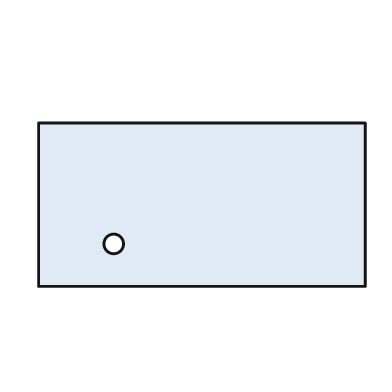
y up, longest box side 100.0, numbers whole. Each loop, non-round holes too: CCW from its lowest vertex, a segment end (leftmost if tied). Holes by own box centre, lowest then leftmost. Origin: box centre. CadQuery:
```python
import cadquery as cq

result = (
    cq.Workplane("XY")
    .moveTo(-50.0, -25.0)
    .lineTo(50.0, -25.0)
    .lineTo(50.0, 25.0)
    .lineTo(-50.0, 25.0)
    .close()
    .moveTo(-27.0, -12.0)
    .circle(3.0)
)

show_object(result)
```